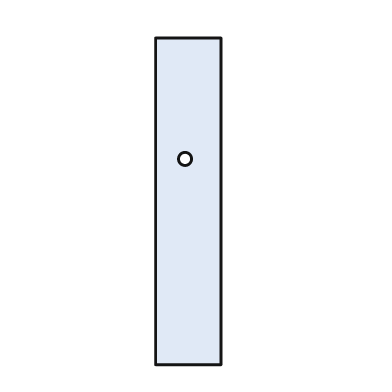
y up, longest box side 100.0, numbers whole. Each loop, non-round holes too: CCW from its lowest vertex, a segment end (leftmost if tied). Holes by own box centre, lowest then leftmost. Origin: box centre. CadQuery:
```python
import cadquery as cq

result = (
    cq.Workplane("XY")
    .moveTo(-10.0, -50.0)
    .lineTo(10.0, -50.0)
    .lineTo(10.0, 50.0)
    .lineTo(-10.0, 50.0)
    .close()
    .moveTo(-1.0, 13.0)
    .circle(2.0)
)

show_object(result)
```